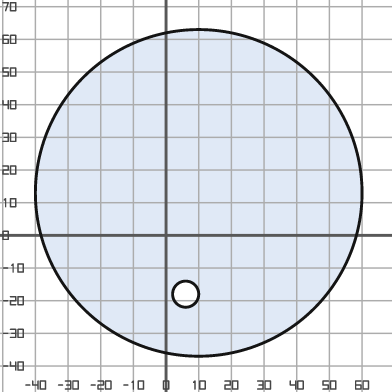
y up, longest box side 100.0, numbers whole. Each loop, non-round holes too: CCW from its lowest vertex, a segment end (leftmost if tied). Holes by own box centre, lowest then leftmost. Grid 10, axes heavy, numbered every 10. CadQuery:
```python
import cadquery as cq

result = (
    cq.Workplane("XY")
    .moveTo(10.0, 13.0)
    .circle(50.0)
    .moveTo(6.0, -18.0)
    .circle(4.0)
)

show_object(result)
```